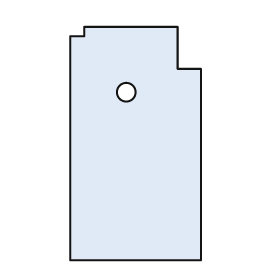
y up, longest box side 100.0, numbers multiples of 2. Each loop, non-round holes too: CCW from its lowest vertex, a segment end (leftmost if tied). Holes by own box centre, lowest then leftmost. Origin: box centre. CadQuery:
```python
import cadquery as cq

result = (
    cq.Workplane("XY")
    .moveTo(-28.0, -50.0)
    .lineTo(28.0, -50.0)
    .lineTo(28.0, 32.0)
    .lineTo(18.0, 32.0)
    .lineTo(18.0, 50.0)
    .lineTo(-22.0, 50.0)
    .lineTo(-22.0, 46.0)
    .lineTo(-28.0, 46.0)
    .close()
    .moveTo(-4.0, 22.0)
    .circle(4.0)
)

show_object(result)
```